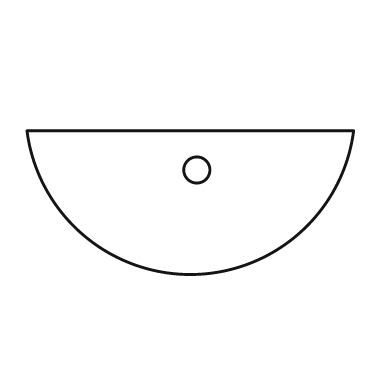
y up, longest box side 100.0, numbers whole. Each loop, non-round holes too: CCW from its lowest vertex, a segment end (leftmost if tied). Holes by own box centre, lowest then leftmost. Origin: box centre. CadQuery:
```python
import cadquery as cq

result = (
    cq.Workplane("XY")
    .moveTo(-50.0, 22.0)
    .threePointArc((0.0, -22.0), (50.0, 22.0))
    .close()
    .moveTo(2.0, 10.0)
    .circle(4.0)
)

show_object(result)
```